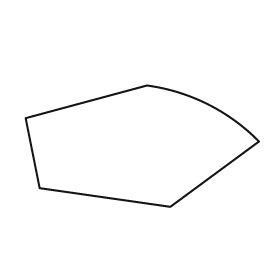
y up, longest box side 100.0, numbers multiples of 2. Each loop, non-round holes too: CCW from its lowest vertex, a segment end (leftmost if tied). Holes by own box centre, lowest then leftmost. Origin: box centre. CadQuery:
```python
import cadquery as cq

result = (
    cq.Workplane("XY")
    .moveTo(12.0, -26.0)
    .lineTo(50.0, 2.0)
    .threePointArc((28.0, 18.0), (2.0, 26.0))
    .lineTo(-50.0, 12.0)
    .lineTo(-44.0, -18.0)
    .close()
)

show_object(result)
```